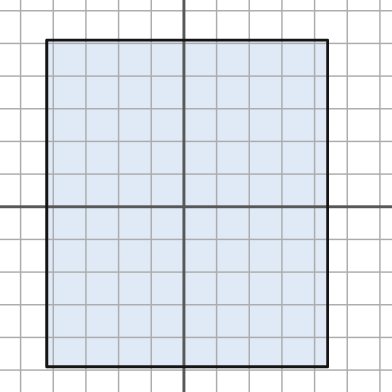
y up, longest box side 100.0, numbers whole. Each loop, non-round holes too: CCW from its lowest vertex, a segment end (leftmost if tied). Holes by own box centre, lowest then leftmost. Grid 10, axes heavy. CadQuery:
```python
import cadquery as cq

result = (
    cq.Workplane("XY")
    .moveTo(-42.0, -49.0)
    .lineTo(44.0, -49.0)
    .lineTo(44.0, 51.0)
    .lineTo(-42.0, 51.0)
    .close()
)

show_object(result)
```